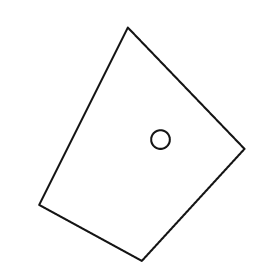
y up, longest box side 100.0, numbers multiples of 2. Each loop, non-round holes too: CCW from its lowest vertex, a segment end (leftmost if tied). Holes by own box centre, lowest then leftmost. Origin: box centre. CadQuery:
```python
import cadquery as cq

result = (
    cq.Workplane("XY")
    .moveTo(0.0, -50.0)
    .lineTo(44.0, -2.0)
    .lineTo(-6.0, 50.0)
    .lineTo(-44.0, -26.0)
    .close()
    .moveTo(8.0, 2.0)
    .circle(4.0)
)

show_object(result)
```